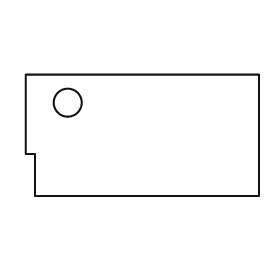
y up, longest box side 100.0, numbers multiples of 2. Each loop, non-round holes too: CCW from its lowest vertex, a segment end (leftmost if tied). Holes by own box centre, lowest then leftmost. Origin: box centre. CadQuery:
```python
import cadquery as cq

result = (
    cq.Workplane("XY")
    .moveTo(-46.0, -26.0)
    .lineTo(50.0, -26.0)
    .lineTo(50.0, 26.0)
    .lineTo(-50.0, 26.0)
    .lineTo(-50.0, -8.0)
    .lineTo(-46.0, -8.0)
    .close()
    .moveTo(-32.0, 14.0)
    .circle(6.0)
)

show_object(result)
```